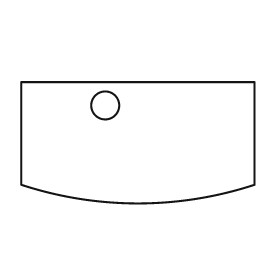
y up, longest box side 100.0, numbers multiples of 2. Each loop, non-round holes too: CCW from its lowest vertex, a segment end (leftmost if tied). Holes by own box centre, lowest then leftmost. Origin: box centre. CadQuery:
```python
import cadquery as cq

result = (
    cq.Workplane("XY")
    .moveTo(-50.0, -18.0)
    .threePointArc((0.0, -26.0), (50.0, -18.0))
    .lineTo(50.0, 26.0)
    .lineTo(-50.0, 26.0)
    .close()
    .moveTo(-14.0, 16.0)
    .circle(6.0)
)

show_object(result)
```